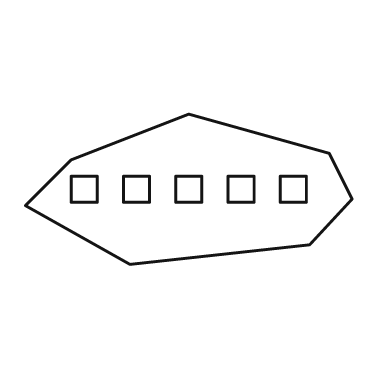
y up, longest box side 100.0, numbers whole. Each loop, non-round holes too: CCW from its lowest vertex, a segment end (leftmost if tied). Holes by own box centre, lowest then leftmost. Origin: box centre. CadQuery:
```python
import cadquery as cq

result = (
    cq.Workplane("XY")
    .moveTo(-18.0, -23.0)
    .lineTo(37.0, -17.0)
    .lineTo(50.0, -3.0)
    .lineTo(43.0, 11.0)
    .lineTo(0.0, 23.0)
    .lineTo(-36.0, 9.0)
    .lineTo(-50.0, -5.0)
    .close()
    .moveTo(-36.0, -4.0)
    .lineTo(-28.0, -4.0)
    .lineTo(-28.0, 4.0)
    .lineTo(-36.0, 4.0)
    .close()
    .moveTo(-20.0, -4.0)
    .lineTo(-12.0, -4.0)
    .lineTo(-12.0, 4.0)
    .lineTo(-20.0, 4.0)
    .close()
    .moveTo(-4.0, -4.0)
    .lineTo(4.0, -4.0)
    .lineTo(4.0, 4.0)
    .lineTo(-4.0, 4.0)
    .close()
    .moveTo(12.0, -4.0)
    .lineTo(20.0, -4.0)
    .lineTo(20.0, 4.0)
    .lineTo(12.0, 4.0)
    .close()
    .moveTo(28.0, -4.0)
    .lineTo(36.0, -4.0)
    .lineTo(36.0, 4.0)
    .lineTo(28.0, 4.0)
    .close()
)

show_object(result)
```